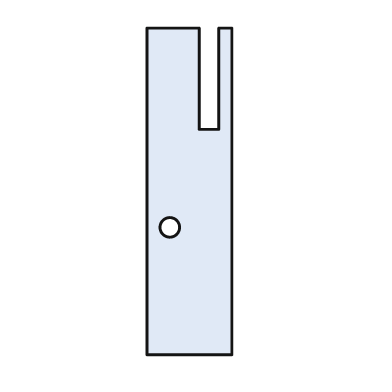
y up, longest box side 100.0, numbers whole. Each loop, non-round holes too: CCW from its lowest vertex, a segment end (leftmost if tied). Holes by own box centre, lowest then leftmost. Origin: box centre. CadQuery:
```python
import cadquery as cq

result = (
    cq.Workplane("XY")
    .moveTo(-13.0, -50.0)
    .lineTo(13.0, -50.0)
    .lineTo(13.0, 50.0)
    .lineTo(9.0, 50.0)
    .lineTo(9.0, 19.0)
    .lineTo(3.0, 19.0)
    .lineTo(3.0, 50.0)
    .lineTo(-13.0, 50.0)
    .close()
    .moveTo(-6.0, -11.0)
    .circle(3.0)
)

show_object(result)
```